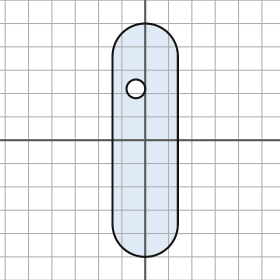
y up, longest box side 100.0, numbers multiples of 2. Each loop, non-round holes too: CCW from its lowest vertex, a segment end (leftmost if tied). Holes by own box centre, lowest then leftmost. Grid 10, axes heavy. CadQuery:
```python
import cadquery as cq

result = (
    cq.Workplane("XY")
    .moveTo(-14.0, -36.0)
    .threePointArc((0.0, -50.0), (14.0, -36.0))
    .lineTo(14.0, 36.0)
    .threePointArc((0.0, 50.0), (-14.0, 36.0))
    .close()
    .moveTo(-4.0, 22.0)
    .circle(4.0)
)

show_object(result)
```